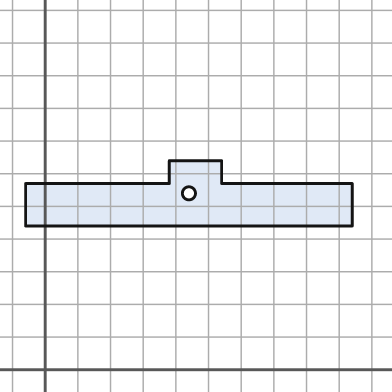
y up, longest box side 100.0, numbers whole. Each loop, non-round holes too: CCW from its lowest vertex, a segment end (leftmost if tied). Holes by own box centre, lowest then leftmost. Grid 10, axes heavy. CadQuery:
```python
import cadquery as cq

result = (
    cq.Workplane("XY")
    .moveTo(-6.0, 44.0)
    .lineTo(94.0, 44.0)
    .lineTo(94.0, 57.0)
    .lineTo(54.0, 57.0)
    .lineTo(54.0, 64.0)
    .lineTo(38.0, 64.0)
    .lineTo(38.0, 57.0)
    .lineTo(-6.0, 57.0)
    .close()
    .moveTo(44.0, 54.0)
    .circle(2.0)
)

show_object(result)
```